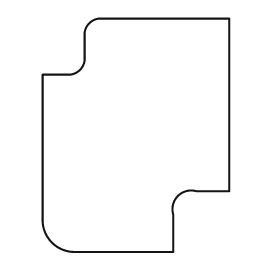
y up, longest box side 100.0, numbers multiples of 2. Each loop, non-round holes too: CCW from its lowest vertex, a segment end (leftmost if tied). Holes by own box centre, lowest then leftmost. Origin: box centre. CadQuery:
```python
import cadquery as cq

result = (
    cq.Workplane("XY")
    .moveTo(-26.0, -50.0)
    .lineTo(16.0, -50.0)
    .lineTo(16.0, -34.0)
    .threePointArc((18.0, -26.0), (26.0, -24.0))
    .lineTo(40.0, -24.0)
    .lineTo(40.0, 50.0)
    .lineTo(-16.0, 50.0)
    .threePointArc((-20.0, 48.0), (-22.0, 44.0))
    .lineTo(-22.0, 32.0)
    .threePointArc((-24.0, 28.0), (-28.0, 26.0))
    .lineTo(-40.0, 26.0)
    .lineTo(-40.0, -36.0)
    .threePointArc((-36.0, -46.0), (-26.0, -50.0))
    .close()
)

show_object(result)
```